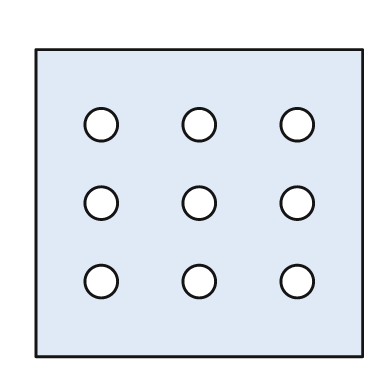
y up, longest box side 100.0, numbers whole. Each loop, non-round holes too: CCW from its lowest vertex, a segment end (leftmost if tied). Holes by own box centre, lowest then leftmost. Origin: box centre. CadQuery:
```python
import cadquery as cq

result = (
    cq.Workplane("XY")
    .moveTo(-50.0, -47.0)
    .lineTo(50.0, -47.0)
    .lineTo(50.0, 47.0)
    .lineTo(-50.0, 47.0)
    .close()
    .moveTo(-30.0, -24.0)
    .circle(5.0)
    .moveTo(0.0, -24.0)
    .circle(5.0)
    .moveTo(30.0, -24.0)
    .circle(5.0)
    .moveTo(-30.0, 0.0)
    .circle(5.0)
    .moveTo(0.0, 0.0)
    .circle(5.0)
    .moveTo(30.0, 0.0)
    .circle(5.0)
    .moveTo(-30.0, 24.0)
    .circle(5.0)
    .moveTo(0.0, 24.0)
    .circle(5.0)
    .moveTo(30.0, 24.0)
    .circle(5.0)
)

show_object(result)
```